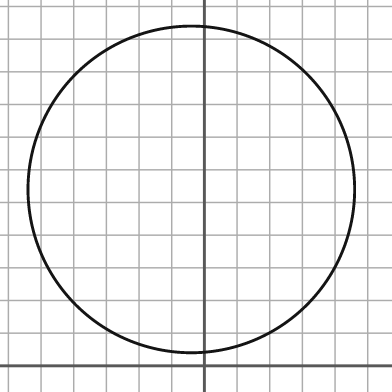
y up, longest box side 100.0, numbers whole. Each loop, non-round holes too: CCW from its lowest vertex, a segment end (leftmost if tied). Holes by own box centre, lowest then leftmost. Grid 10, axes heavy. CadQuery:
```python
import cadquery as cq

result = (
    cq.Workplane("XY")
    .moveTo(-4.0, 54.0)
    .circle(50.0)
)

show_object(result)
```